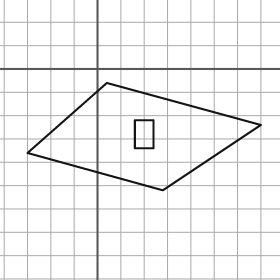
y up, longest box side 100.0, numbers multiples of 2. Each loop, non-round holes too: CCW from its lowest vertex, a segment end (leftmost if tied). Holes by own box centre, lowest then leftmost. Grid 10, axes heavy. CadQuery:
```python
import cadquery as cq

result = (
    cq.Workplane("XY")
    .moveTo(28.0, -52.0)
    .lineTo(70.0, -24.0)
    .lineTo(4.0, -6.0)
    .lineTo(-30.0, -36.0)
    .close()
    .moveTo(16.0, -34.0)
    .lineTo(24.0, -34.0)
    .lineTo(24.0, -22.0)
    .lineTo(16.0, -22.0)
    .close()
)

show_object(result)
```